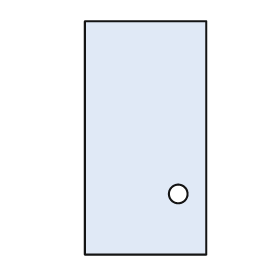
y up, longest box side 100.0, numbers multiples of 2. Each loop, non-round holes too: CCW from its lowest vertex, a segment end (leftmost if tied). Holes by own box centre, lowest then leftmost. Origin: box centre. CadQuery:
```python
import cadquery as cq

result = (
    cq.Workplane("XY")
    .moveTo(-26.0, -50.0)
    .lineTo(26.0, -50.0)
    .lineTo(26.0, 50.0)
    .lineTo(-26.0, 50.0)
    .close()
    .moveTo(14.0, -24.0)
    .circle(4.0)
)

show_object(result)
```